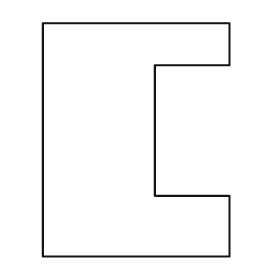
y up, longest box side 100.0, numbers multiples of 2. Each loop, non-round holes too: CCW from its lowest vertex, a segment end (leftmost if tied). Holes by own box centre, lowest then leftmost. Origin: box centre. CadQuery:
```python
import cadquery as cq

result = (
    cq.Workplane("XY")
    .moveTo(-40.0, -50.0)
    .lineTo(40.0, -50.0)
    .lineTo(40.0, -24.0)
    .lineTo(8.0, -24.0)
    .lineTo(8.0, 32.0)
    .lineTo(40.0, 32.0)
    .lineTo(40.0, 50.0)
    .lineTo(-40.0, 50.0)
    .close()
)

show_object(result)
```